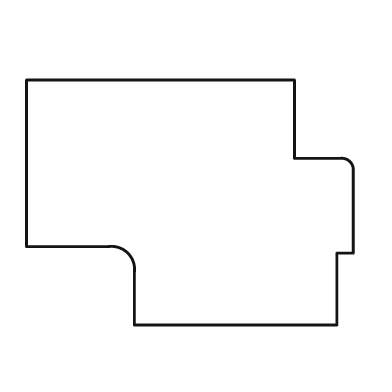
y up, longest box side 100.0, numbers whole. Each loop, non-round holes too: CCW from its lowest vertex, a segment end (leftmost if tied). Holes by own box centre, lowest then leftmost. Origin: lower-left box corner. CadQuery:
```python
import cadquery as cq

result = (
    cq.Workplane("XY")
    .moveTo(33.0, 0.0)
    .lineTo(95.0, 0.0)
    .lineTo(95.0, 22.0)
    .lineTo(100.0, 22.0)
    .lineTo(100.0, 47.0)
    .threePointArc((99.0, 50.0), (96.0, 51.0))
    .lineTo(82.0, 51.0)
    .lineTo(82.0, 75.0)
    .lineTo(0.0, 75.0)
    .lineTo(0.0, 24.0)
    .lineTo(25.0, 24.0)
    .threePointArc((31.0, 22.0), (33.0, 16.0))
    .close()
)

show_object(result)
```